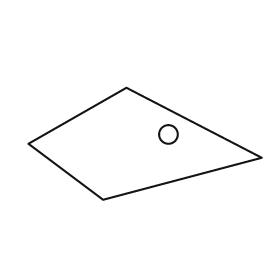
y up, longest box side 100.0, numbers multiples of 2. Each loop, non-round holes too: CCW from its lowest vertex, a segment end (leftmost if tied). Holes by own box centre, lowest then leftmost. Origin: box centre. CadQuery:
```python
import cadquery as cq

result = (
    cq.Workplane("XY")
    .moveTo(-18.0, -24.0)
    .lineTo(50.0, -6.0)
    .lineTo(-8.0, 24.0)
    .lineTo(-50.0, 0.0)
    .close()
    .moveTo(10.0, 4.0)
    .circle(4.0)
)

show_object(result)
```